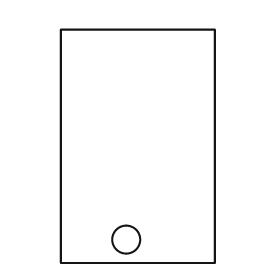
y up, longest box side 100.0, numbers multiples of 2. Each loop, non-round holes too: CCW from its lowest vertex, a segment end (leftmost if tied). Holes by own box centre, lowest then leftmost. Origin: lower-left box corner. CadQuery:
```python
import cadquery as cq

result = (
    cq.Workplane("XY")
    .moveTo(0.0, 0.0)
    .lineTo(66.0, 0.0)
    .lineTo(66.0, 100.0)
    .lineTo(0.0, 100.0)
    .close()
    .moveTo(28.0, 10.0)
    .circle(6.0)
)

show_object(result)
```